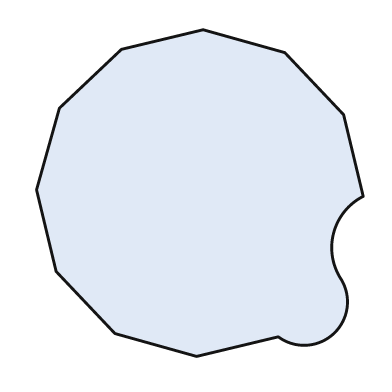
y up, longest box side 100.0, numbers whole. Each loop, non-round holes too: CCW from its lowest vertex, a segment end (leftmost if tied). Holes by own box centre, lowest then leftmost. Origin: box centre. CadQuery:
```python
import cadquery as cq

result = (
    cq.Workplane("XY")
    .moveTo(-1.0, -50.0)
    .lineTo(24.0, -44.0)
    .threePointArc((41.0, -43.0), (43.0, -26.0))
    .threePointArc((41.0, -12.0), (50.0, -1.0))
    .lineTo(44.0, 24.0)
    .lineTo(26.0, 43.0)
    .lineTo(1.0, 50.0)
    .lineTo(-24.0, 44.0)
    .lineTo(-43.0, 26.0)
    .lineTo(-50.0, 1.0)
    .lineTo(-44.0, -24.0)
    .lineTo(-26.0, -43.0)
    .close()
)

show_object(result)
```